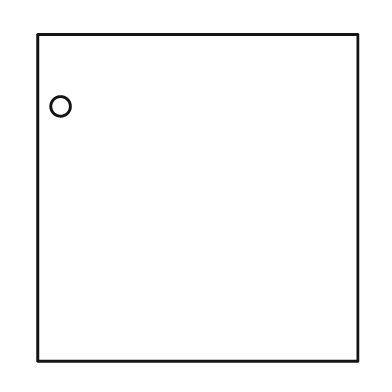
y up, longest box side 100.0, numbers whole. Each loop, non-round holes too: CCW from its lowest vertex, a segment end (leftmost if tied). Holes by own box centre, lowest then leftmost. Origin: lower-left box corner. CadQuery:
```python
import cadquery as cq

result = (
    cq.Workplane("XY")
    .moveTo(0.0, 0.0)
    .lineTo(98.0, 0.0)
    .lineTo(98.0, 100.0)
    .lineTo(0.0, 100.0)
    .close()
    .moveTo(7.0, 78.0)
    .circle(3.0)
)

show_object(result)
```